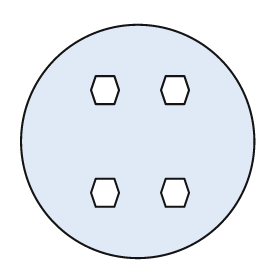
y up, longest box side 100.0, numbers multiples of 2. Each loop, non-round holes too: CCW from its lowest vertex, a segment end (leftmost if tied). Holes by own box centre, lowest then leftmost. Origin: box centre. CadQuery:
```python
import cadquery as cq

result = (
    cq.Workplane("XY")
    .moveTo(0.0, 0.0)
    .circle(50.0)
    .moveTo(-18.0, -28.0)
    .lineTo(-10.0, -28.0)
    .lineTo(-8.0, -22.0)
    .lineTo(-10.0, -16.0)
    .lineTo(-18.0, -16.0)
    .lineTo(-20.0, -22.0)
    .close()
    .moveTo(12.0, -28.0)
    .lineTo(20.0, -28.0)
    .lineTo(22.0, -22.0)
    .lineTo(20.0, -16.0)
    .lineTo(12.0, -16.0)
    .lineTo(10.0, -22.0)
    .close()
    .moveTo(-18.0, 16.0)
    .lineTo(-10.0, 16.0)
    .lineTo(-8.0, 22.0)
    .lineTo(-10.0, 28.0)
    .lineTo(-18.0, 28.0)
    .lineTo(-20.0, 22.0)
    .close()
    .moveTo(12.0, 16.0)
    .lineTo(20.0, 16.0)
    .lineTo(22.0, 22.0)
    .lineTo(20.0, 28.0)
    .lineTo(12.0, 28.0)
    .lineTo(10.0, 22.0)
    .close()
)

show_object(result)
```